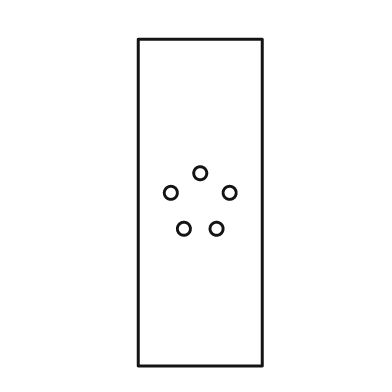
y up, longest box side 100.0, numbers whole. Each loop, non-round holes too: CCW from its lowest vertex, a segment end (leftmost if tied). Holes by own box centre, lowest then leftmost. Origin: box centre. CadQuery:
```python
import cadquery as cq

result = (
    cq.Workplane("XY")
    .moveTo(-19.0, -50.0)
    .lineTo(19.0, -50.0)
    .lineTo(19.0, 50.0)
    .lineTo(-19.0, 50.0)
    .close()
    .moveTo(-5.0, -8.0)
    .circle(2.0)
    .moveTo(5.0, -8.0)
    .circle(2.0)
    .moveTo(-9.0, 3.0)
    .circle(2.0)
    .moveTo(9.0, 3.0)
    .circle(2.0)
    .moveTo(0.0, 9.0)
    .circle(2.0)
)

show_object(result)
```